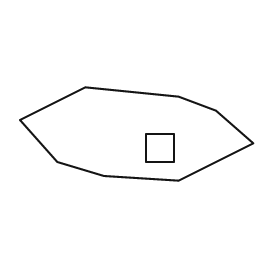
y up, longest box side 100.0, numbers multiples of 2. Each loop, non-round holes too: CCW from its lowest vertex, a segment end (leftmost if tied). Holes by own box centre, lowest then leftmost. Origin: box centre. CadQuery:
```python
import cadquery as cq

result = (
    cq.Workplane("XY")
    .moveTo(18.0, -20.0)
    .lineTo(50.0, -4.0)
    .lineTo(34.0, 10.0)
    .lineTo(18.0, 16.0)
    .lineTo(-22.0, 20.0)
    .lineTo(-50.0, 6.0)
    .lineTo(-34.0, -12.0)
    .lineTo(-14.0, -18.0)
    .close()
    .moveTo(4.0, -12.0)
    .lineTo(16.0, -12.0)
    .lineTo(16.0, 0.0)
    .lineTo(4.0, 0.0)
    .close()
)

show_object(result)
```